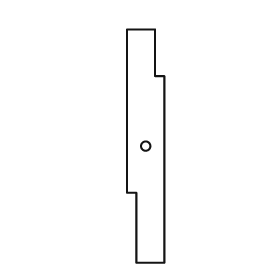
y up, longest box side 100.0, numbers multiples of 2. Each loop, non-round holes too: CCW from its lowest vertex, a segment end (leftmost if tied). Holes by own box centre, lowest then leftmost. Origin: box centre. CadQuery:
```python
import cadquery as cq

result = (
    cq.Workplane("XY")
    .moveTo(-4.0, -50.0)
    .lineTo(8.0, -50.0)
    .lineTo(8.0, 30.0)
    .lineTo(4.0, 30.0)
    .lineTo(4.0, 50.0)
    .lineTo(-8.0, 50.0)
    .lineTo(-8.0, -20.0)
    .lineTo(-4.0, -20.0)
    .close()
    .moveTo(0.0, 0.0)
    .circle(2.0)
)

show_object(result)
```